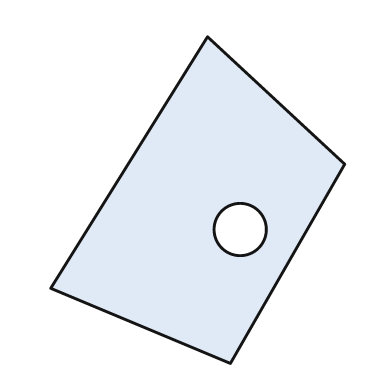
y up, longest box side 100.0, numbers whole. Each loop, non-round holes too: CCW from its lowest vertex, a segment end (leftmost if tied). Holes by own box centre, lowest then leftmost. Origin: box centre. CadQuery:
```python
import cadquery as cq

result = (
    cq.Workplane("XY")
    .moveTo(10.0, -50.0)
    .lineTo(45.0, 11.0)
    .lineTo(3.0, 50.0)
    .lineTo(-45.0, -27.0)
    .close()
    .moveTo(13.0, -9.0)
    .circle(8.0)
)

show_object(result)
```